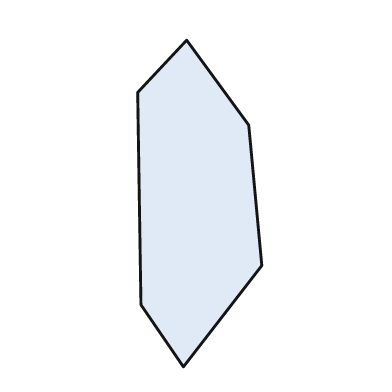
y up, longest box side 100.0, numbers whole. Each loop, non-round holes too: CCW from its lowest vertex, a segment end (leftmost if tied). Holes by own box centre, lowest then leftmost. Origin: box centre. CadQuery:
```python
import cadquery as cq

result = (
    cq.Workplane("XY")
    .moveTo(-5.0, -50.0)
    .lineTo(19.0, -19.0)
    .lineTo(15.0, 24.0)
    .lineTo(-4.0, 50.0)
    .lineTo(-19.0, 34.0)
    .lineTo(-18.0, -31.0)
    .close()
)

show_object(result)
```